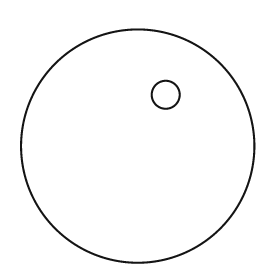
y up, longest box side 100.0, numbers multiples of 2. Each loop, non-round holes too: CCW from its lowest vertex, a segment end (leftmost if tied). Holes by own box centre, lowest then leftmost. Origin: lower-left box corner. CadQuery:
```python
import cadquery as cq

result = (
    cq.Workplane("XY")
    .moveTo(50.0, 50.0)
    .circle(50.0)
    .moveTo(62.0, 72.0)
    .circle(6.0)
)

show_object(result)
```